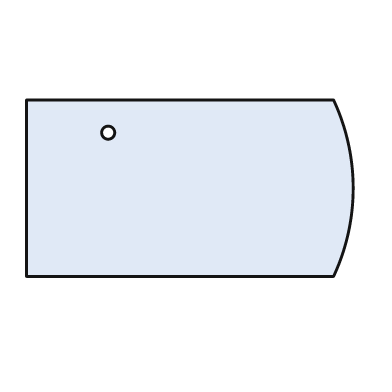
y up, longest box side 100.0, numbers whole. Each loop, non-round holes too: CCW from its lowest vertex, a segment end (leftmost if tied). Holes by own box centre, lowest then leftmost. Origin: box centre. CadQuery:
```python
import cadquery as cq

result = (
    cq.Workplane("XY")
    .moveTo(-50.0, -27.0)
    .lineTo(44.0, -27.0)
    .threePointArc((50.0, 0.0), (44.0, 27.0))
    .lineTo(-50.0, 27.0)
    .close()
    .moveTo(-25.0, 17.0)
    .circle(2.0)
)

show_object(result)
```